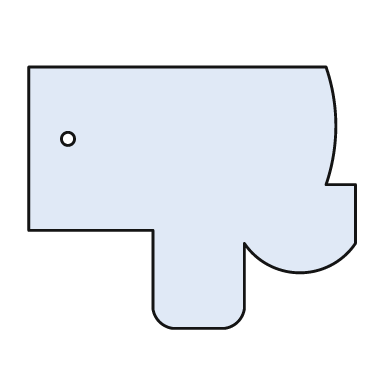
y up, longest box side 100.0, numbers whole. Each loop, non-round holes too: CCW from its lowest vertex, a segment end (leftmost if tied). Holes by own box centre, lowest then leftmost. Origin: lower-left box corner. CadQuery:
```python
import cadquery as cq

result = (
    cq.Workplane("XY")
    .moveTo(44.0, 0.0)
    .lineTo(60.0, 0.0)
    .threePointArc((64.0, 2.0), (66.0, 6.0))
    .lineTo(66.0, 26.0)
    .threePointArc((83.0, 17.0), (100.0, 26.0))
    .lineTo(100.0, 44.0)
    .lineTo(91.0, 44.0)
    .threePointArc((94.0, 62.0), (91.0, 80.0))
    .lineTo(0.0, 80.0)
    .lineTo(0.0, 30.0)
    .lineTo(38.0, 30.0)
    .lineTo(38.0, 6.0)
    .threePointArc((40.0, 2.0), (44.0, 0.0))
    .close()
    .moveTo(12.0, 58.0)
    .circle(2.0)
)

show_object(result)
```